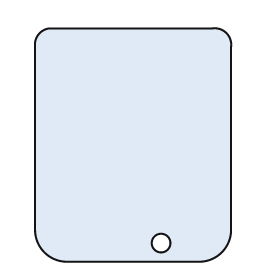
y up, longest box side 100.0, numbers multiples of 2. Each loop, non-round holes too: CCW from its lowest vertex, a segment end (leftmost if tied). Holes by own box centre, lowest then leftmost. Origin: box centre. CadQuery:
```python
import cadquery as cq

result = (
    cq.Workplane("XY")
    .moveTo(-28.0, -50.0)
    .lineTo(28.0, -50.0)
    .threePointArc((38.0, -46.0), (42.0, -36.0))
    .lineTo(42.0, 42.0)
    .threePointArc((40.0, 48.0), (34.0, 50.0))
    .lineTo(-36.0, 50.0)
    .threePointArc((-40.0, 48.0), (-42.0, 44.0))
    .lineTo(-42.0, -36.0)
    .threePointArc((-38.0, -46.0), (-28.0, -50.0))
    .close()
    .moveTo(12.0, -42.0)
    .circle(4.0)
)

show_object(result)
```